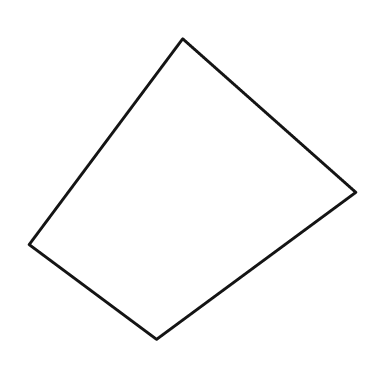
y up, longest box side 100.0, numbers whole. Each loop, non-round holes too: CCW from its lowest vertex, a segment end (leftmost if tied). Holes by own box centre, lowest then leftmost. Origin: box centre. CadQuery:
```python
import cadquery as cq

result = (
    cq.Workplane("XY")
    .moveTo(-11.0, -46.0)
    .lineTo(50.0, -1.0)
    .lineTo(-3.0, 46.0)
    .lineTo(-50.0, -17.0)
    .close()
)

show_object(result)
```